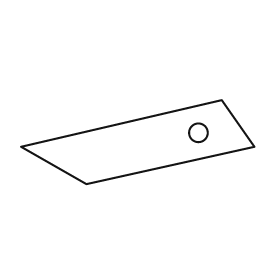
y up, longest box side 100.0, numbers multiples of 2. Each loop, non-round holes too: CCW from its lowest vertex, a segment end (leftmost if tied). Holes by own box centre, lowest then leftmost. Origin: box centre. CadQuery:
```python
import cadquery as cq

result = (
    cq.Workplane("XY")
    .moveTo(-22.0, -18.0)
    .lineTo(50.0, -2.0)
    .lineTo(36.0, 18.0)
    .lineTo(-50.0, -2.0)
    .close()
    .moveTo(26.0, 4.0)
    .circle(4.0)
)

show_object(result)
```